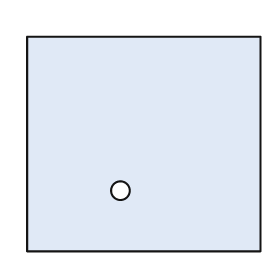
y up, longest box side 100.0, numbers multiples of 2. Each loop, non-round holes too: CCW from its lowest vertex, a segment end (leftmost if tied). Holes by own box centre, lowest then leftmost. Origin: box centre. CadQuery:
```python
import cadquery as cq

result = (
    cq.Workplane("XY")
    .moveTo(-50.0, -46.0)
    .lineTo(50.0, -46.0)
    .lineTo(50.0, 46.0)
    .lineTo(-50.0, 46.0)
    .close()
    .moveTo(-10.0, -20.0)
    .circle(4.0)
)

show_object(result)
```